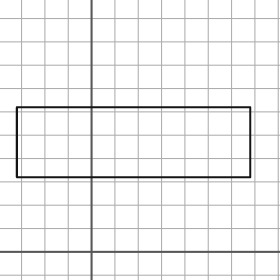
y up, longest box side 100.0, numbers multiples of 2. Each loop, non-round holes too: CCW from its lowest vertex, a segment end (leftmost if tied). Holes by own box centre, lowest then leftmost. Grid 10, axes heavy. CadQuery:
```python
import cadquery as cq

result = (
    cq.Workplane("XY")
    .moveTo(-32.0, 32.0)
    .lineTo(68.0, 32.0)
    .lineTo(68.0, 62.0)
    .lineTo(-32.0, 62.0)
    .close()
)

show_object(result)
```